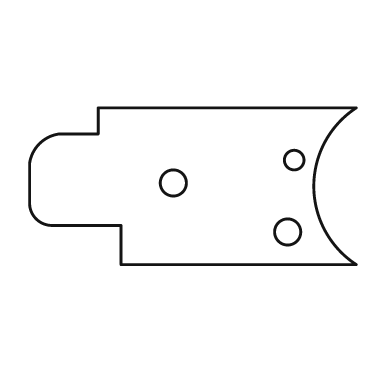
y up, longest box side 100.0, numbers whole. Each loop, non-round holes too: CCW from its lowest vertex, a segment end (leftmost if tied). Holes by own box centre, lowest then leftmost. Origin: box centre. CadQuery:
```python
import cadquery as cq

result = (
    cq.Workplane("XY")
    .moveTo(-22.0, -24.0)
    .lineTo(50.0, -24.0)
    .threePointArc((37.0, 0.0), (50.0, 24.0))
    .lineTo(-29.0, 24.0)
    .lineTo(-29.0, 16.0)
    .lineTo(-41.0, 16.0)
    .threePointArc((-47.0, 13.0), (-50.0, 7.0))
    .lineTo(-50.0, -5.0)
    .threePointArc((-48.0, -10.0), (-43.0, -12.0))
    .lineTo(-22.0, -12.0)
    .close()
    .moveTo(29.0, -14.0)
    .circle(4.0)
    .moveTo(-6.0, 1.0)
    .circle(4.0)
    .moveTo(31.0, 8.0)
    .circle(3.0)
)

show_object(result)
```